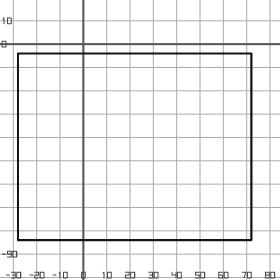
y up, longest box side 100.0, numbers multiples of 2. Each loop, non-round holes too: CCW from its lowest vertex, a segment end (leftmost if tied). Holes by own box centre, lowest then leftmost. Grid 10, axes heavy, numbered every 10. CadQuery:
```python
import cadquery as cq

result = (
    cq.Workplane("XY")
    .moveTo(-28.0, -84.0)
    .lineTo(72.0, -84.0)
    .lineTo(72.0, -4.0)
    .lineTo(-28.0, -4.0)
    .close()
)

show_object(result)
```